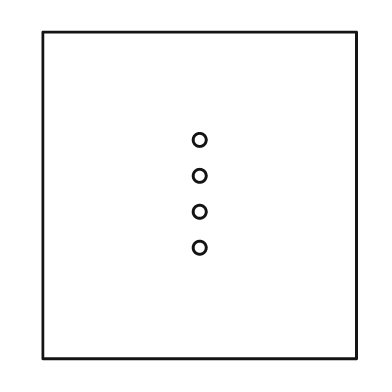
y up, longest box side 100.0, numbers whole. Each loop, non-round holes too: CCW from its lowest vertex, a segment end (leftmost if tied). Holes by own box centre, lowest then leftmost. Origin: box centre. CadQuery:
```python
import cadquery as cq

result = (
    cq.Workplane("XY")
    .moveTo(-48.0, -50.0)
    .lineTo(48.0, -50.0)
    .lineTo(48.0, 50.0)
    .lineTo(-48.0, 50.0)
    .close()
    .moveTo(0.0, -16.0)
    .circle(2.0)
    .moveTo(0.0, -5.0)
    .circle(2.0)
    .moveTo(0.0, 6.0)
    .circle(2.0)
    .moveTo(0.0, 17.0)
    .circle(2.0)
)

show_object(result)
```